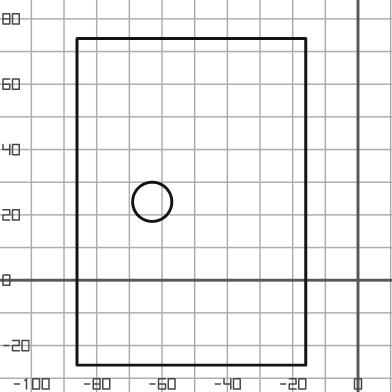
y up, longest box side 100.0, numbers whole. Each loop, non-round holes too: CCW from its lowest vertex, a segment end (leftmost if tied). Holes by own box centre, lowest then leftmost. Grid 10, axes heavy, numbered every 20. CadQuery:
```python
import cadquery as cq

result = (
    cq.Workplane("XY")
    .moveTo(-86.0, -26.0)
    .lineTo(-16.0, -26.0)
    .lineTo(-16.0, 74.0)
    .lineTo(-86.0, 74.0)
    .close()
    .moveTo(-63.0, 24.0)
    .circle(6.0)
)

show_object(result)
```